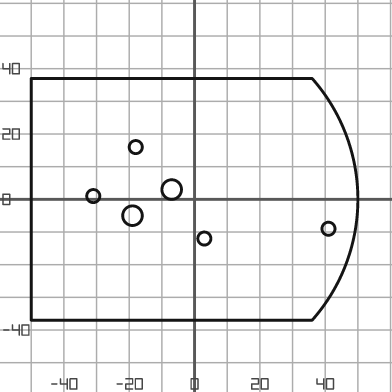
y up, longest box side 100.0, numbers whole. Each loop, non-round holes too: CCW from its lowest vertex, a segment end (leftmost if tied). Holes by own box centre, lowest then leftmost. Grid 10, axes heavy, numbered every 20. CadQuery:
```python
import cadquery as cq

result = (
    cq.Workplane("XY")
    .moveTo(-50.0, -37.0)
    .lineTo(36.0, -37.0)
    .threePointArc((50.0, 0.0), (36.0, 37.0))
    .lineTo(-50.0, 37.0)
    .close()
    .moveTo(3.0, -12.0)
    .circle(2.0)
    .moveTo(41.0, -9.0)
    .circle(2.0)
    .moveTo(-19.0, -5.0)
    .circle(3.0)
    .moveTo(-31.0, 1.0)
    .circle(2.0)
    .moveTo(-7.0, 3.0)
    .circle(3.0)
    .moveTo(-18.0, 16.0)
    .circle(2.0)
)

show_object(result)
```